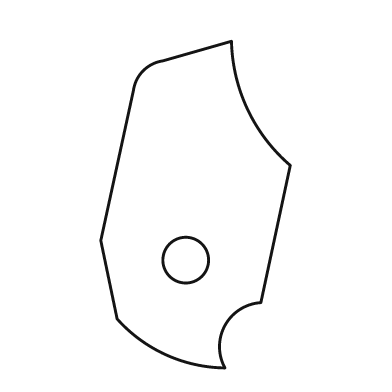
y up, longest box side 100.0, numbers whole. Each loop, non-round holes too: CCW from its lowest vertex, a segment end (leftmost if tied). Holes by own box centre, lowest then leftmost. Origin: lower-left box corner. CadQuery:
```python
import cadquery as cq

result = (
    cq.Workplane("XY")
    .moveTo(38.0, 0.0)
    .threePointArc((38.0, 13.0), (49.0, 20.0))
    .lineTo(58.0, 62.0)
    .threePointArc((45.0, 79.0), (40.0, 100.0))
    .lineTo(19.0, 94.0)
    .threePointArc((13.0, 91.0), (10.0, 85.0))
    .lineTo(0.0, 39.0)
    .lineTo(5.0, 15.0)
    .threePointArc((20.0, 4.0), (38.0, 0.0))
    .close()
    .moveTo(26.0, 33.0)
    .circle(7.0)
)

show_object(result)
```